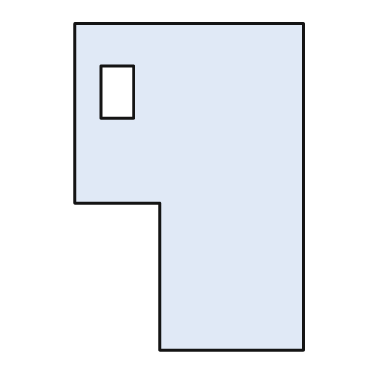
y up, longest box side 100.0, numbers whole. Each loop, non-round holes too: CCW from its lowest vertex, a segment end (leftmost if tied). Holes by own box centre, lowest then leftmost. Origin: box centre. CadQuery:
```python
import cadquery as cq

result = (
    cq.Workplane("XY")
    .moveTo(-9.0, -50.0)
    .lineTo(35.0, -50.0)
    .lineTo(35.0, 50.0)
    .lineTo(-35.0, 50.0)
    .lineTo(-35.0, -5.0)
    .lineTo(-9.0, -5.0)
    .close()
    .moveTo(-27.0, 21.0)
    .lineTo(-17.0, 21.0)
    .lineTo(-17.0, 37.0)
    .lineTo(-27.0, 37.0)
    .close()
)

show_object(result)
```